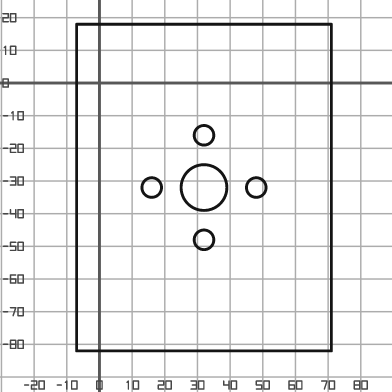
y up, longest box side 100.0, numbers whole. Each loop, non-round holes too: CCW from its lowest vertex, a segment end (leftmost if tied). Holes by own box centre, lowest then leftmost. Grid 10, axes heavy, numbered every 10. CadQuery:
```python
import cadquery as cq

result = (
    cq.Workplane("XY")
    .moveTo(-7.0, -82.0)
    .lineTo(71.0, -82.0)
    .lineTo(71.0, 18.0)
    .lineTo(-7.0, 18.0)
    .close()
    .moveTo(32.0, -48.0)
    .circle(3.0)
    .moveTo(16.0, -32.0)
    .circle(3.0)
    .moveTo(32.0, -32.0)
    .circle(7.0)
    .moveTo(48.0, -32.0)
    .circle(3.0)
    .moveTo(32.0, -16.0)
    .circle(3.0)
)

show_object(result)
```